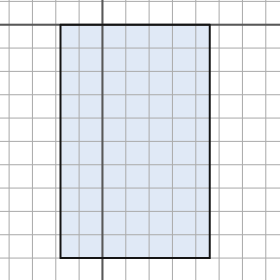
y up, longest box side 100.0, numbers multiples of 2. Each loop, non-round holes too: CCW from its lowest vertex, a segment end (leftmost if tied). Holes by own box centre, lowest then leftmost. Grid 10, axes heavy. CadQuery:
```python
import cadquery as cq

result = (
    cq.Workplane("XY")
    .moveTo(-18.0, -100.0)
    .lineTo(46.0, -100.0)
    .lineTo(46.0, 0.0)
    .lineTo(-18.0, 0.0)
    .close()
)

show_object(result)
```